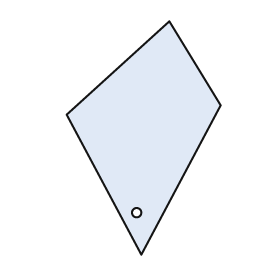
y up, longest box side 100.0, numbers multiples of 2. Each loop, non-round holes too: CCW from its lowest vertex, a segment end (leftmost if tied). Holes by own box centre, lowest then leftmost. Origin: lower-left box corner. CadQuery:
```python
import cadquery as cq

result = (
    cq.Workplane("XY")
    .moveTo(32.0, 0.0)
    .lineTo(66.0, 64.0)
    .lineTo(44.0, 100.0)
    .lineTo(0.0, 60.0)
    .close()
    .moveTo(30.0, 18.0)
    .circle(2.0)
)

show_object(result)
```